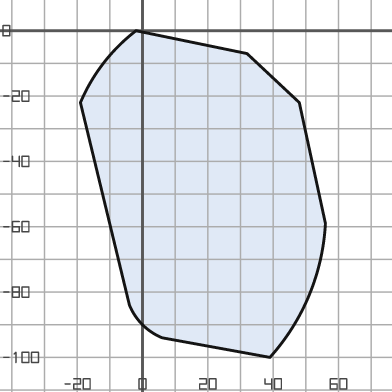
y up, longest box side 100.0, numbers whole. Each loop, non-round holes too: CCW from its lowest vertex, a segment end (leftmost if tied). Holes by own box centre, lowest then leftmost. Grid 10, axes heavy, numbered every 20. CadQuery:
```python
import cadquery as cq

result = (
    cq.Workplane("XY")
    .moveTo(39.0, -100.0)
    .threePointArc((51.0, -81.0), (56.0, -59.0))
    .lineTo(48.0, -22.0)
    .lineTo(32.0, -7.0)
    .lineTo(-2.0, 0.0)
    .threePointArc((-12.0, -10.0), (-19.0, -22.0))
    .lineTo(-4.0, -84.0)
    .threePointArc((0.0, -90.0), (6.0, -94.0))
    .close()
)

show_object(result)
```